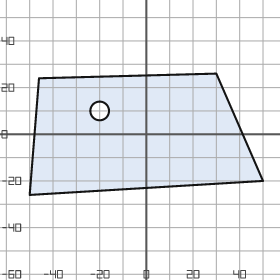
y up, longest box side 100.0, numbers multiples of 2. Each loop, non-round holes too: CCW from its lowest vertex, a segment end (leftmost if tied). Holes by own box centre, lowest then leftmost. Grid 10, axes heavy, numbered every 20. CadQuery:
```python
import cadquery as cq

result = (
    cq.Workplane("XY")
    .moveTo(-50.0, -26.0)
    .lineTo(50.0, -20.0)
    .lineTo(30.0, 26.0)
    .lineTo(-46.0, 24.0)
    .close()
    .moveTo(-20.0, 10.0)
    .circle(4.0)
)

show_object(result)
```